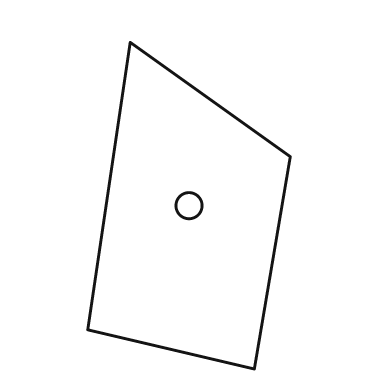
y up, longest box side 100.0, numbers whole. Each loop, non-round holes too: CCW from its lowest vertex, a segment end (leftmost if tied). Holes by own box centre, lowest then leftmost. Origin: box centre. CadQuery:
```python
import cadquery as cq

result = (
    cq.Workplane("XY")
    .moveTo(20.0, -50.0)
    .lineTo(31.0, 15.0)
    .lineTo(-18.0, 50.0)
    .lineTo(-31.0, -38.0)
    .close()
    .moveTo(0.0, 0.0)
    .circle(4.0)
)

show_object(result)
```